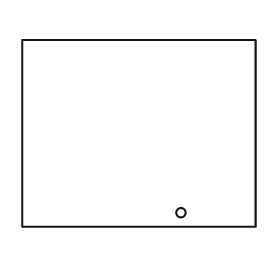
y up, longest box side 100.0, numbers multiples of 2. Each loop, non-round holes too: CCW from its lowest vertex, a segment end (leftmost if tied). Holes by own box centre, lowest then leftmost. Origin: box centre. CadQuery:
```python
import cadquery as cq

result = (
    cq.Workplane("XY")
    .moveTo(-50.0, -40.0)
    .lineTo(50.0, -40.0)
    .lineTo(50.0, 40.0)
    .lineTo(-50.0, 40.0)
    .close()
    .moveTo(18.0, -34.0)
    .circle(2.0)
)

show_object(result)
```